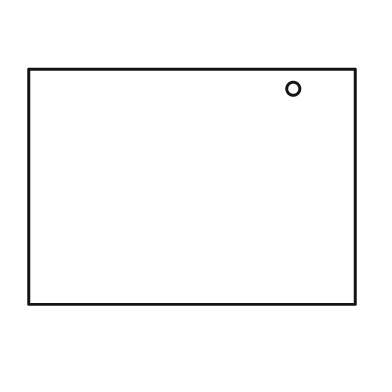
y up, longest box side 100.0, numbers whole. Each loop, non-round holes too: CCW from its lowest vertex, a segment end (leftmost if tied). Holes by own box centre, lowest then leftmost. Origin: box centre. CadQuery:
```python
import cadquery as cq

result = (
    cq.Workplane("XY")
    .moveTo(-50.0, -36.0)
    .lineTo(50.0, -36.0)
    .lineTo(50.0, 36.0)
    .lineTo(-50.0, 36.0)
    .close()
    .moveTo(31.0, 30.0)
    .circle(2.0)
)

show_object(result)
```